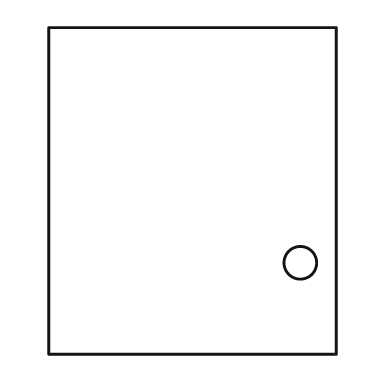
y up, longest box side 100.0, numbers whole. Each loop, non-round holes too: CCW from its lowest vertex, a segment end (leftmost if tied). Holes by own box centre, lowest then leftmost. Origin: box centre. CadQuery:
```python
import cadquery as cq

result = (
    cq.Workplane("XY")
    .moveTo(-44.0, -50.0)
    .lineTo(44.0, -50.0)
    .lineTo(44.0, 50.0)
    .lineTo(-44.0, 50.0)
    .close()
    .moveTo(33.0, -22.0)
    .circle(5.0)
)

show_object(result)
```